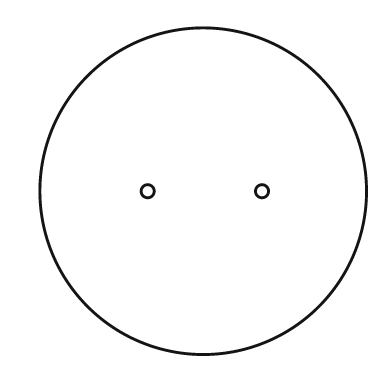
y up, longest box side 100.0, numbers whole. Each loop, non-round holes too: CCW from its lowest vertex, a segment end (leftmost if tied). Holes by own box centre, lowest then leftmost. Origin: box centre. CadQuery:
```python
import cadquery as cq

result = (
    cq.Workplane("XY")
    .moveTo(0.0, 0.0)
    .circle(50.0)
    .moveTo(-17.0, 0.0)
    .circle(2.0)
    .moveTo(18.0, 0.0)
    .circle(2.0)
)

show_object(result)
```